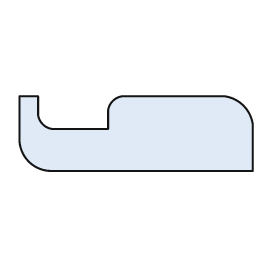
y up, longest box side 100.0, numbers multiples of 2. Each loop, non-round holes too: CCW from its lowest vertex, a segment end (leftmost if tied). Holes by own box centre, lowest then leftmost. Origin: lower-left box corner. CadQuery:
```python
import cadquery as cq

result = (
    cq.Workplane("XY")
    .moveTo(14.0, 0.0)
    .lineTo(100.0, 0.0)
    .lineTo(100.0, 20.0)
    .threePointArc((96.0, 28.0), (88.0, 32.0))
    .lineTo(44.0, 32.0)
    .threePointArc((40.0, 30.0), (38.0, 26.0))
    .lineTo(38.0, 18.0)
    .lineTo(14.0, 18.0)
    .threePointArc((10.0, 20.0), (8.0, 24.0))
    .lineTo(8.0, 32.0)
    .lineTo(0.0, 32.0)
    .lineTo(0.0, 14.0)
    .threePointArc((4.0, 4.0), (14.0, 0.0))
    .close()
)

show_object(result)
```